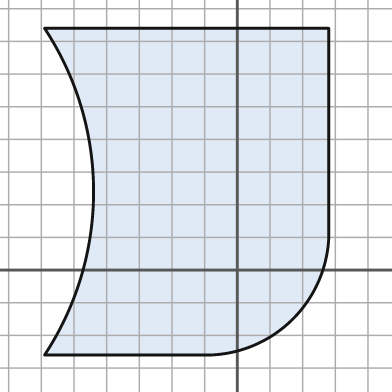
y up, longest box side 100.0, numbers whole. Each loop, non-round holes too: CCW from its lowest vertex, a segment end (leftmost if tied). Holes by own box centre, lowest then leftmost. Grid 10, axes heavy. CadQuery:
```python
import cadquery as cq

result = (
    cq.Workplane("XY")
    .moveTo(-59.0, -26.0)
    .lineTo(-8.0, -26.0)
    .threePointArc((17.0, -15.0), (28.0, 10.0))
    .lineTo(28.0, 74.0)
    .lineTo(-59.0, 74.0)
    .threePointArc((-44.0, 24.0), (-59.0, -26.0))
    .close()
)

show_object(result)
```